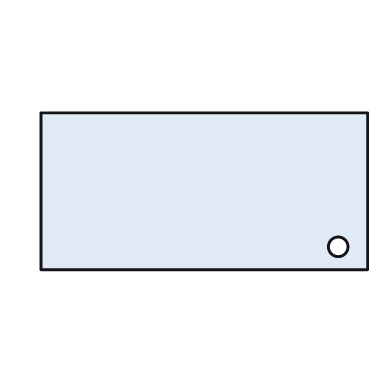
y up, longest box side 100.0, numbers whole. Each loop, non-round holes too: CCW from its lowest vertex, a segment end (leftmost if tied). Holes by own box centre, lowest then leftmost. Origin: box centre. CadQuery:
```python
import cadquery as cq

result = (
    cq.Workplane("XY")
    .moveTo(-50.0, -24.0)
    .lineTo(50.0, -24.0)
    .lineTo(50.0, 24.0)
    .lineTo(-50.0, 24.0)
    .close()
    .moveTo(41.0, -17.0)
    .circle(3.0)
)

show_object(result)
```